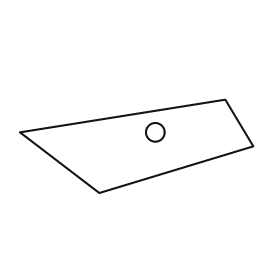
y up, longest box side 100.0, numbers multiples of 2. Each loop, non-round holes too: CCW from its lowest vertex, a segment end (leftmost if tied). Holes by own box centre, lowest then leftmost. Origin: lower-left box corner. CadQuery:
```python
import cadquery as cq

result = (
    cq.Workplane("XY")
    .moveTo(34.0, 0.0)
    .lineTo(100.0, 20.0)
    .lineTo(88.0, 40.0)
    .lineTo(0.0, 26.0)
    .close()
    .moveTo(58.0, 26.0)
    .circle(4.0)
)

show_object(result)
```